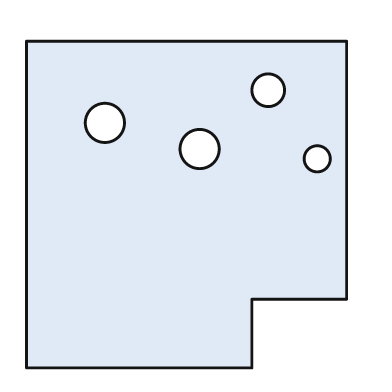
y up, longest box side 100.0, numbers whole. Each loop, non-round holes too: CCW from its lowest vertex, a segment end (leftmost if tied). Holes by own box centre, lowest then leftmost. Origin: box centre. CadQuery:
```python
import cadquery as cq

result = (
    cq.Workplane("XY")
    .moveTo(-49.0, -50.0)
    .lineTo(20.0, -50.0)
    .lineTo(20.0, -29.0)
    .lineTo(49.0, -29.0)
    .lineTo(49.0, 50.0)
    .lineTo(-49.0, 50.0)
    .close()
    .moveTo(40.0, 14.0)
    .circle(4.0)
    .moveTo(4.0, 17.0)
    .circle(6.0)
    .moveTo(-25.0, 25.0)
    .circle(6.0)
    .moveTo(25.0, 35.0)
    .circle(5.0)
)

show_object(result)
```